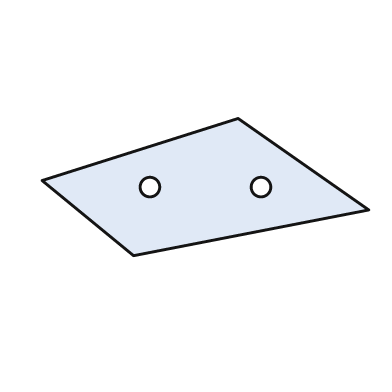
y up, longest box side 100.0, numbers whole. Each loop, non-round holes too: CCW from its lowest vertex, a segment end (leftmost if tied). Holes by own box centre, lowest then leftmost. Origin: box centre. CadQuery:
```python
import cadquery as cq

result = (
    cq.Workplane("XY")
    .moveTo(-22.0, -21.0)
    .lineTo(50.0, -7.0)
    .lineTo(10.0, 21.0)
    .lineTo(-50.0, 2.0)
    .close()
    .moveTo(-17.0, 0.0)
    .circle(3.0)
    .moveTo(17.0, 0.0)
    .circle(3.0)
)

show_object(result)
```